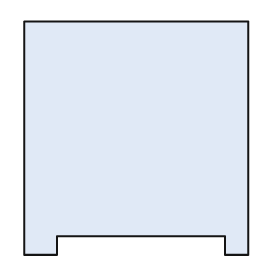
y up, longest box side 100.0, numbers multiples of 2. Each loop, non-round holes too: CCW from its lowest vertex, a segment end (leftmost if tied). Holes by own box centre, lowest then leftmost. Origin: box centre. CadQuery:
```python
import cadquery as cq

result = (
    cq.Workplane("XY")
    .moveTo(-48.0, -50.0)
    .lineTo(-34.0, -50.0)
    .lineTo(-34.0, -42.0)
    .lineTo(38.0, -42.0)
    .lineTo(38.0, -50.0)
    .lineTo(48.0, -50.0)
    .lineTo(48.0, 50.0)
    .lineTo(-48.0, 50.0)
    .close()
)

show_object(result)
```